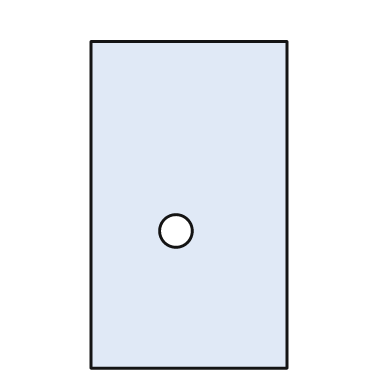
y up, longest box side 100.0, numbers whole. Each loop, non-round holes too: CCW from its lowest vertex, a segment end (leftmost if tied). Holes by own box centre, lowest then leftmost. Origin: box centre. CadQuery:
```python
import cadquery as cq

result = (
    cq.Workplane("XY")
    .moveTo(-30.0, -50.0)
    .lineTo(30.0, -50.0)
    .lineTo(30.0, 50.0)
    .lineTo(-30.0, 50.0)
    .close()
    .moveTo(-4.0, -8.0)
    .circle(5.0)
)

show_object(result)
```